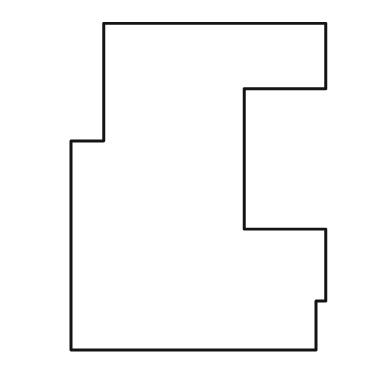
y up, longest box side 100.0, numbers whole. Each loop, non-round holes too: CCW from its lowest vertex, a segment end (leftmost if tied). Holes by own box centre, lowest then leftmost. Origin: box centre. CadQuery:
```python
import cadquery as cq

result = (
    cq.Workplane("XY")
    .moveTo(-39.0, -50.0)
    .lineTo(36.0, -50.0)
    .lineTo(36.0, -35.0)
    .lineTo(39.0, -35.0)
    .lineTo(39.0, -13.0)
    .lineTo(14.0, -13.0)
    .lineTo(14.0, 30.0)
    .lineTo(39.0, 30.0)
    .lineTo(39.0, 50.0)
    .lineTo(-29.0, 50.0)
    .lineTo(-29.0, 14.0)
    .lineTo(-39.0, 14.0)
    .close()
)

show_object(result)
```